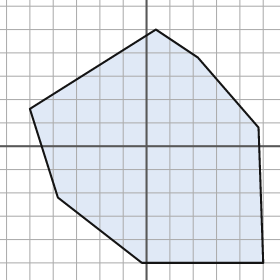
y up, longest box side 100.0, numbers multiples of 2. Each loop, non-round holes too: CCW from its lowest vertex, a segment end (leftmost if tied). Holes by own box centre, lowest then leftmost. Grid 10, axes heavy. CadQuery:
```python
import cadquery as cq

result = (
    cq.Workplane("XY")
    .moveTo(-2.0, -50.0)
    .lineTo(50.0, -50.0)
    .lineTo(48.0, 8.0)
    .lineTo(22.0, 38.0)
    .lineTo(4.0, 50.0)
    .lineTo(-50.0, 16.0)
    .lineTo(-38.0, -22.0)
    .close()
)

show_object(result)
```